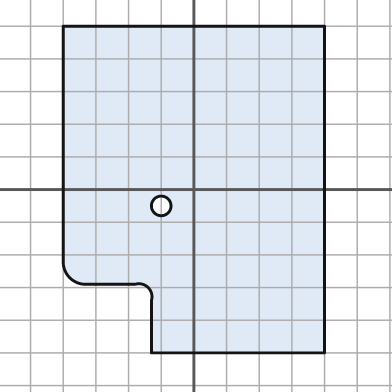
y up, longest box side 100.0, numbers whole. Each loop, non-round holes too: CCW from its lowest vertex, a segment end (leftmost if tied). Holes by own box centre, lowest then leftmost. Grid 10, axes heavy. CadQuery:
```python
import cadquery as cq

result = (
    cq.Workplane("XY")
    .moveTo(-13.0, -50.0)
    .lineTo(40.0, -50.0)
    .lineTo(40.0, 50.0)
    .lineTo(-40.0, 50.0)
    .lineTo(-40.0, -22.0)
    .threePointArc((-38.0, -27.0), (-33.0, -29.0))
    .lineTo(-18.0, -29.0)
    .threePointArc((-14.0, -30.0), (-13.0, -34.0))
    .close()
    .moveTo(-10.0, -5.0)
    .circle(3.0)
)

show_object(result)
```